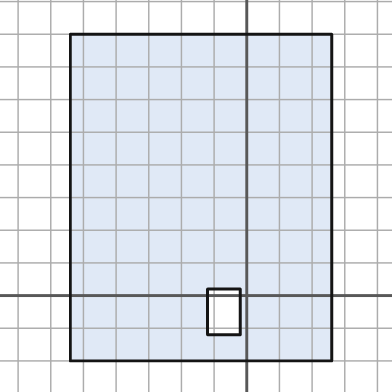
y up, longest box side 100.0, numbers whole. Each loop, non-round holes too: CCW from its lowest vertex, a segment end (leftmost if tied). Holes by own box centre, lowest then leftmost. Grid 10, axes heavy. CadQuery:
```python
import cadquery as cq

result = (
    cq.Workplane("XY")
    .moveTo(-54.0, -20.0)
    .lineTo(26.0, -20.0)
    .lineTo(26.0, 80.0)
    .lineTo(-54.0, 80.0)
    .close()
    .moveTo(-12.0, -12.0)
    .lineTo(-2.0, -12.0)
    .lineTo(-2.0, 2.0)
    .lineTo(-12.0, 2.0)
    .close()
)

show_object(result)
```